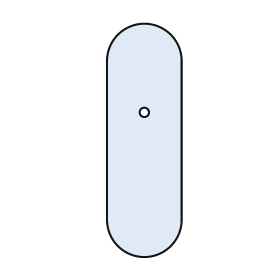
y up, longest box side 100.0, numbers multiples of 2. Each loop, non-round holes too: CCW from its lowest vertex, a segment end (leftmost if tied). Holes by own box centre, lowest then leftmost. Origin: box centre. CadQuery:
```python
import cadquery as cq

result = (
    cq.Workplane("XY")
    .moveTo(-16.0, -34.0)
    .threePointArc((0.0, -50.0), (16.0, -34.0))
    .lineTo(16.0, 34.0)
    .threePointArc((0.0, 50.0), (-16.0, 34.0))
    .close()
    .moveTo(0.0, 12.0)
    .circle(2.0)
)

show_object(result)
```